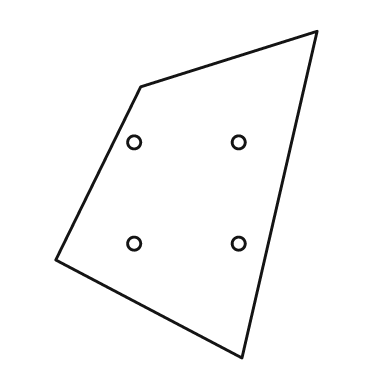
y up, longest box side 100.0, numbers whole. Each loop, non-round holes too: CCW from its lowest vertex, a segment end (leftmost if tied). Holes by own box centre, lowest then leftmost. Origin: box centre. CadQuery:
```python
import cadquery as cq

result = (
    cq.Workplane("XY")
    .moveTo(17.0, -50.0)
    .lineTo(40.0, 50.0)
    .lineTo(-14.0, 33.0)
    .lineTo(-40.0, -20.0)
    .close()
    .moveTo(-16.0, -15.0)
    .circle(2.0)
    .moveTo(16.0, -15.0)
    .circle(2.0)
    .moveTo(-16.0, 16.0)
    .circle(2.0)
    .moveTo(16.0, 16.0)
    .circle(2.0)
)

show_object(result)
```